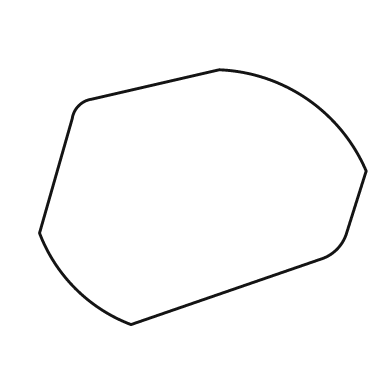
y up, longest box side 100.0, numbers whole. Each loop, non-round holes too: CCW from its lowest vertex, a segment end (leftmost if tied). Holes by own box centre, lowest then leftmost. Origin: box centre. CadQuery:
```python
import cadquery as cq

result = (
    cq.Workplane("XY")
    .moveTo(-22.0, -39.0)
    .lineTo(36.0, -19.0)
    .threePointArc((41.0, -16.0), (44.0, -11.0))
    .lineTo(50.0, 8.0)
    .threePointArc((32.0, 30.0), (5.0, 39.0))
    .lineTo(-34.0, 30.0)
    .threePointArc((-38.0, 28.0), (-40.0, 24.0))
    .lineTo(-50.0, -11.0)
    .threePointArc((-39.0, -28.0), (-22.0, -39.0))
    .close()
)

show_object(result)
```